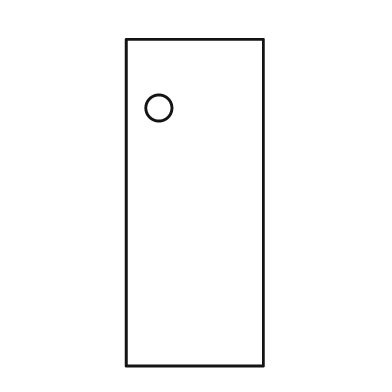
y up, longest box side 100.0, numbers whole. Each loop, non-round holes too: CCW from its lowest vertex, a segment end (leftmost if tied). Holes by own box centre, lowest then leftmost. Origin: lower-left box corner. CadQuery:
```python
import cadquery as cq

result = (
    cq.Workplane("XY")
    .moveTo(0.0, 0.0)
    .lineTo(42.0, 0.0)
    .lineTo(42.0, 100.0)
    .lineTo(0.0, 100.0)
    .close()
    .moveTo(10.0, 79.0)
    .circle(4.0)
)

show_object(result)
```